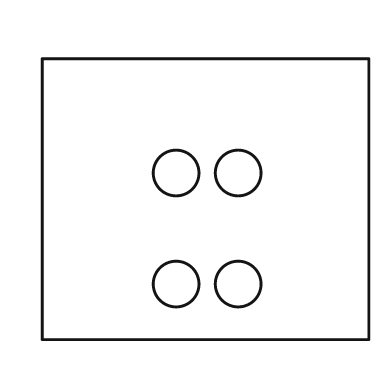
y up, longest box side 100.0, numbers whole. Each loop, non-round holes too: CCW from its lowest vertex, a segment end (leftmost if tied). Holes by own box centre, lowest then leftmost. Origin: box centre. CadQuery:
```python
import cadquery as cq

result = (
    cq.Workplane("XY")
    .moveTo(-50.0, -43.0)
    .lineTo(50.0, -43.0)
    .lineTo(50.0, 43.0)
    .lineTo(-50.0, 43.0)
    .close()
    .moveTo(-9.0, -26.0)
    .circle(7.0)
    .moveTo(10.0, -26.0)
    .circle(7.0)
    .moveTo(-9.0, 8.0)
    .circle(7.0)
    .moveTo(10.0, 8.0)
    .circle(7.0)
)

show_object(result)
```